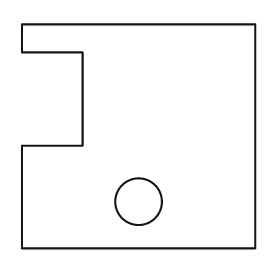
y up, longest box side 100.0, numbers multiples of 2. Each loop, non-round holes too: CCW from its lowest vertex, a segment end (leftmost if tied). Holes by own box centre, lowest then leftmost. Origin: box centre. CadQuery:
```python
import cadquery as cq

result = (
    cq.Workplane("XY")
    .moveTo(-50.0, -48.0)
    .lineTo(50.0, -48.0)
    .lineTo(50.0, 48.0)
    .lineTo(-50.0, 48.0)
    .lineTo(-50.0, 36.0)
    .lineTo(-24.0, 36.0)
    .lineTo(-24.0, -4.0)
    .lineTo(-50.0, -4.0)
    .close()
    .moveTo(0.0, -28.0)
    .circle(10.0)
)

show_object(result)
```